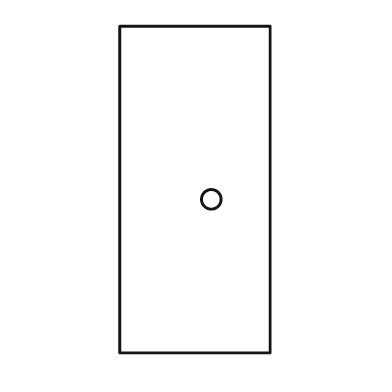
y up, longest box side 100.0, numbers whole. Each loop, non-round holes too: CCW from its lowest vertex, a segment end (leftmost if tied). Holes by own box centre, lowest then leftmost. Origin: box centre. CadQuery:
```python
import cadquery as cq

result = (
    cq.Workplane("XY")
    .moveTo(-23.0, -50.0)
    .lineTo(23.0, -50.0)
    .lineTo(23.0, 50.0)
    .lineTo(-23.0, 50.0)
    .close()
    .moveTo(5.0, -3.0)
    .circle(3.0)
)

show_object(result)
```